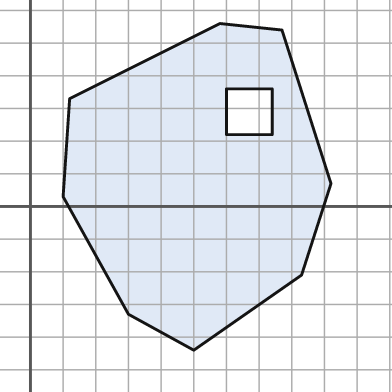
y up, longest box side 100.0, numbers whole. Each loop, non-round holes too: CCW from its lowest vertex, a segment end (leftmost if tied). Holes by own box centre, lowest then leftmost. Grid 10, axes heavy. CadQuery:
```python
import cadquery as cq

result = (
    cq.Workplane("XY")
    .moveTo(50.0, -44.0)
    .lineTo(83.0, -21.0)
    .lineTo(92.0, 7.0)
    .lineTo(77.0, 54.0)
    .lineTo(58.0, 56.0)
    .lineTo(12.0, 33.0)
    .lineTo(10.0, 3.0)
    .lineTo(30.0, -33.0)
    .close()
    .moveTo(60.0, 22.0)
    .lineTo(74.0, 22.0)
    .lineTo(74.0, 36.0)
    .lineTo(60.0, 36.0)
    .close()
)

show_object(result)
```